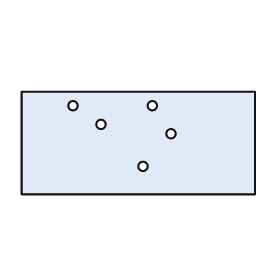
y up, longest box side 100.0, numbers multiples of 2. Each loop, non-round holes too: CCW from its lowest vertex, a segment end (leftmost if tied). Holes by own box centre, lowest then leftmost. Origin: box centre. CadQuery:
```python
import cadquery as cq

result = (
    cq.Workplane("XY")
    .moveTo(-50.0, -22.0)
    .lineTo(50.0, -22.0)
    .lineTo(50.0, 22.0)
    .lineTo(-50.0, 22.0)
    .close()
    .moveTo(2.0, -10.0)
    .circle(2.0)
    .moveTo(14.0, 4.0)
    .circle(2.0)
    .moveTo(-16.0, 8.0)
    .circle(2.0)
    .moveTo(-28.0, 16.0)
    .circle(2.0)
    .moveTo(6.0, 16.0)
    .circle(2.0)
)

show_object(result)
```